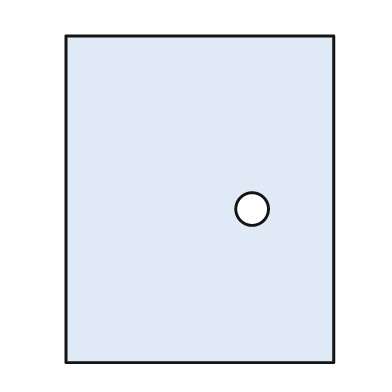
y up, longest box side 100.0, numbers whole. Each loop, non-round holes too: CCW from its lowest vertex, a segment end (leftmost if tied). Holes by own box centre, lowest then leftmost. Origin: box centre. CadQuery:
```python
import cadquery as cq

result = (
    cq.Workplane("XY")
    .moveTo(-41.0, -50.0)
    .lineTo(41.0, -50.0)
    .lineTo(41.0, 50.0)
    .lineTo(-41.0, 50.0)
    .close()
    .moveTo(16.0, -3.0)
    .circle(5.0)
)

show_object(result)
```